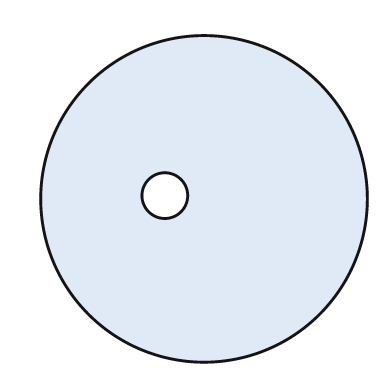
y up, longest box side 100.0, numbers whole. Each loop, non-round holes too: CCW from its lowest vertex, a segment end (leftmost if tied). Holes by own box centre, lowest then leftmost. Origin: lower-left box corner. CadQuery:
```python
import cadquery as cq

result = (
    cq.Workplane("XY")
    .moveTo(50.0, 50.0)
    .circle(50.0)
    .moveTo(38.0, 51.0)
    .circle(7.0)
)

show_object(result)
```